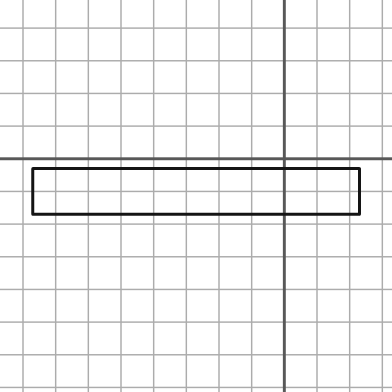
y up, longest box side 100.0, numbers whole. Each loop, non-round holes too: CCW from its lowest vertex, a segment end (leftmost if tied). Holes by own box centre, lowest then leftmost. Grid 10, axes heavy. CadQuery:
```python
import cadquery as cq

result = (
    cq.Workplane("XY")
    .moveTo(-77.0, -17.0)
    .lineTo(23.0, -17.0)
    .lineTo(23.0, -3.0)
    .lineTo(-77.0, -3.0)
    .close()
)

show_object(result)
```